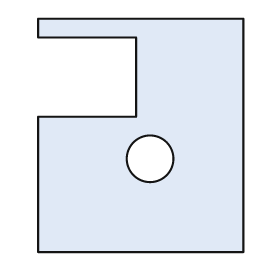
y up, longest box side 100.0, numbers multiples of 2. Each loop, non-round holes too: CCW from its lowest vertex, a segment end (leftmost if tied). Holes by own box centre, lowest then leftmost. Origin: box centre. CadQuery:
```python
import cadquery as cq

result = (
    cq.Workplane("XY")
    .moveTo(-44.0, -50.0)
    .lineTo(44.0, -50.0)
    .lineTo(44.0, 50.0)
    .lineTo(-44.0, 50.0)
    .lineTo(-44.0, 42.0)
    .lineTo(-2.0, 42.0)
    .lineTo(-2.0, 8.0)
    .lineTo(-44.0, 8.0)
    .close()
    .moveTo(4.0, -10.0)
    .circle(10.0)
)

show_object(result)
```